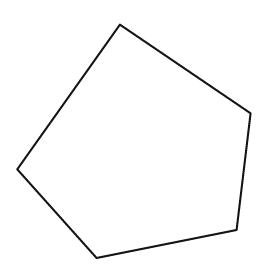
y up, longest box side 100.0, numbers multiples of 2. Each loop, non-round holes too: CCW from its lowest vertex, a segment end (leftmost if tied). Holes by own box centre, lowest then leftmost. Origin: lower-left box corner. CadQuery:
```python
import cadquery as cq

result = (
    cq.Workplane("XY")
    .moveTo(34.0, 0.0)
    .lineTo(94.0, 12.0)
    .lineTo(100.0, 62.0)
    .lineTo(44.0, 100.0)
    .lineTo(0.0, 38.0)
    .close()
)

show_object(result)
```